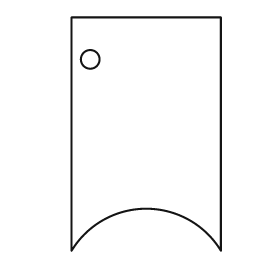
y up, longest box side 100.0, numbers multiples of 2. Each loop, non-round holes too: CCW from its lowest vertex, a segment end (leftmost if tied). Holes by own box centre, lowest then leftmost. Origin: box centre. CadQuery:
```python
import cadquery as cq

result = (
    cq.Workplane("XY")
    .moveTo(-32.0, -50.0)
    .threePointArc((0.0, -32.0), (32.0, -50.0))
    .lineTo(32.0, 50.0)
    .lineTo(-32.0, 50.0)
    .close()
    .moveTo(-24.0, 32.0)
    .circle(4.0)
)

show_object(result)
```